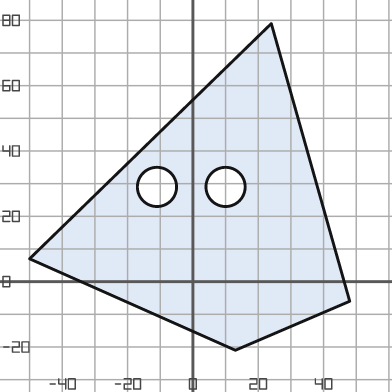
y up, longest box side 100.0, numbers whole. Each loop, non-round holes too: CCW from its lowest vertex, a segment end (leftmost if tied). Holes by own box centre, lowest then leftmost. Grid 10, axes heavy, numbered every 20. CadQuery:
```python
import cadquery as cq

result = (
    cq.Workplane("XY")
    .moveTo(13.0, -21.0)
    .lineTo(48.0, -6.0)
    .lineTo(24.0, 79.0)
    .lineTo(-50.0, 7.0)
    .close()
    .moveTo(-11.0, 29.0)
    .circle(6.0)
    .moveTo(10.0, 29.0)
    .circle(6.0)
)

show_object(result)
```